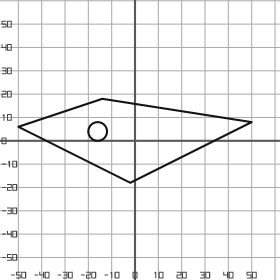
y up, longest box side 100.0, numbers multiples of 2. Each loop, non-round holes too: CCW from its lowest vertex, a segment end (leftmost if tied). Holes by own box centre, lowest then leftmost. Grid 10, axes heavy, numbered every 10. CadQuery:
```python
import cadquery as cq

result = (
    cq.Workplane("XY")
    .moveTo(-2.0, -18.0)
    .lineTo(50.0, 8.0)
    .lineTo(-14.0, 18.0)
    .lineTo(-50.0, 6.0)
    .close()
    .moveTo(-16.0, 4.0)
    .circle(4.0)
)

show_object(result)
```